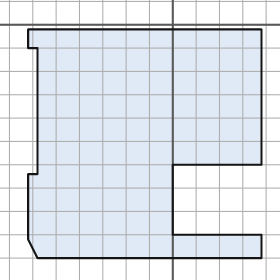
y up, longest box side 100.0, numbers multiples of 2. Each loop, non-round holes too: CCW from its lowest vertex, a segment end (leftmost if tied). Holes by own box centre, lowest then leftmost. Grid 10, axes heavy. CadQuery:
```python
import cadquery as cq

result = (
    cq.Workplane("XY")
    .moveTo(-58.0, -100.0)
    .lineTo(38.0, -100.0)
    .lineTo(38.0, -90.0)
    .lineTo(0.0, -90.0)
    .lineTo(0.0, -60.0)
    .lineTo(38.0, -60.0)
    .lineTo(38.0, -2.0)
    .lineTo(-62.0, -2.0)
    .lineTo(-62.0, -10.0)
    .lineTo(-58.0, -10.0)
    .lineTo(-58.0, -64.0)
    .lineTo(-62.0, -64.0)
    .lineTo(-62.0, -92.0)
    .close()
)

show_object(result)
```